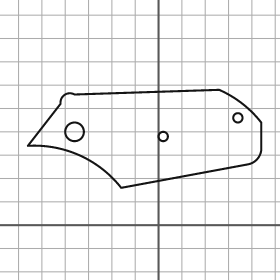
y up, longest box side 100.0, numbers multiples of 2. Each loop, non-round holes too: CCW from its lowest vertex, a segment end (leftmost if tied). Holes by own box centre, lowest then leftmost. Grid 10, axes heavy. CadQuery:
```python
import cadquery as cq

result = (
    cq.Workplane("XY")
    .moveTo(-16.0, 16.0)
    .lineTo(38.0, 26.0)
    .threePointArc((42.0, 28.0), (44.0, 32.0))
    .lineTo(44.0, 44.0)
    .threePointArc((36.0, 52.0), (26.0, 58.0))
    .lineTo(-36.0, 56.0)
    .threePointArc((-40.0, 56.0), (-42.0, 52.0))
    .lineTo(-56.0, 34.0)
    .threePointArc((-34.0, 30.0), (-16.0, 16.0))
    .close()
    .moveTo(2.0, 38.0)
    .circle(2.0)
    .moveTo(-36.0, 40.0)
    .circle(4.0)
    .moveTo(34.0, 46.0)
    .circle(2.0)
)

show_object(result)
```